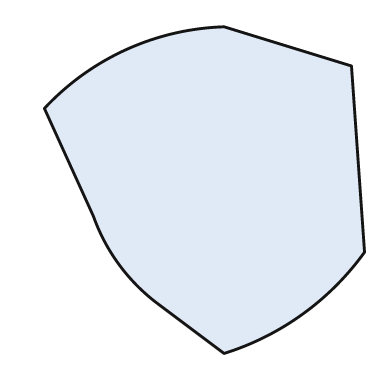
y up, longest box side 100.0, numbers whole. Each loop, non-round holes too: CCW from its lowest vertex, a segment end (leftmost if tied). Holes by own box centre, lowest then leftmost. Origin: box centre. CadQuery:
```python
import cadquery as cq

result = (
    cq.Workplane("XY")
    .moveTo(6.0, -50.0)
    .threePointArc((30.0, -38.0), (49.0, -19.0))
    .lineTo(45.0, 38.0)
    .lineTo(6.0, 50.0)
    .threePointArc((-24.0, 43.0), (-49.0, 25.0))
    .lineTo(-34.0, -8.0)
    .threePointArc((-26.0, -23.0), (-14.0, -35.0))
    .close()
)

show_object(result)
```